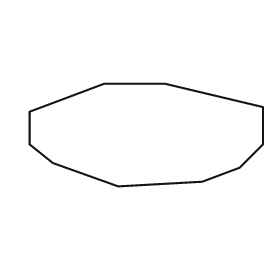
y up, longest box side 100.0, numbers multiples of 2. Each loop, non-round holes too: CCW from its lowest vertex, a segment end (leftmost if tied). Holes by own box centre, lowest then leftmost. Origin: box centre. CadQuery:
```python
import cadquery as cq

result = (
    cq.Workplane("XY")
    .moveTo(-12.0, -22.0)
    .lineTo(24.0, -20.0)
    .lineTo(40.0, -14.0)
    .lineTo(50.0, -4.0)
    .lineTo(50.0, 12.0)
    .lineTo(8.0, 22.0)
    .lineTo(-18.0, 22.0)
    .lineTo(-50.0, 10.0)
    .lineTo(-50.0, -4.0)
    .lineTo(-40.0, -12.0)
    .close()
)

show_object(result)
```